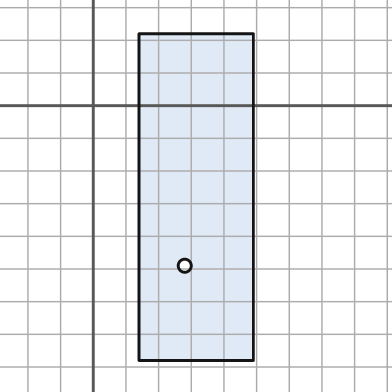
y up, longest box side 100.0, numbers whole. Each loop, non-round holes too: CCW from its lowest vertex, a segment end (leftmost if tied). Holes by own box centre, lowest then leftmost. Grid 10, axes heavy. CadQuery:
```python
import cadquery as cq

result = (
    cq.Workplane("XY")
    .moveTo(14.0, -78.0)
    .lineTo(49.0, -78.0)
    .lineTo(49.0, 22.0)
    .lineTo(14.0, 22.0)
    .close()
    .moveTo(28.0, -49.0)
    .circle(2.0)
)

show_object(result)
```